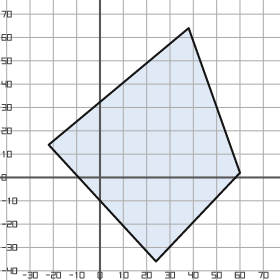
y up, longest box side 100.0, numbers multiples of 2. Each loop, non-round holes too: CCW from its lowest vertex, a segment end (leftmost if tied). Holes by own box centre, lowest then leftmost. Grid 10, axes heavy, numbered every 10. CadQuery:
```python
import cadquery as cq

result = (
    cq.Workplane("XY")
    .moveTo(24.0, -36.0)
    .lineTo(60.0, 2.0)
    .lineTo(38.0, 64.0)
    .lineTo(-22.0, 14.0)
    .close()
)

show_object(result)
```